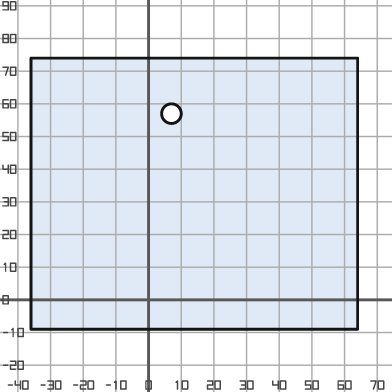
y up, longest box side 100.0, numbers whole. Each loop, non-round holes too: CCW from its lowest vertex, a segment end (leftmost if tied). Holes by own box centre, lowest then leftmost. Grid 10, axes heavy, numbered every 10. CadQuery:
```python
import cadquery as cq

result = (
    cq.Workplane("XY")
    .moveTo(-36.0, -9.0)
    .lineTo(64.0, -9.0)
    .lineTo(64.0, 74.0)
    .lineTo(-36.0, 74.0)
    .close()
    .moveTo(7.0, 57.0)
    .circle(3.0)
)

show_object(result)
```